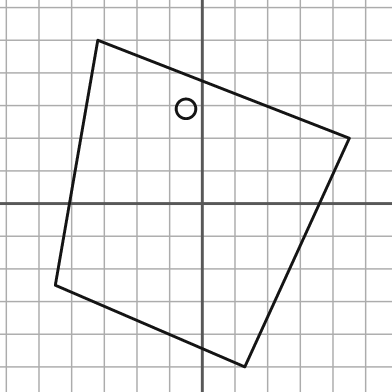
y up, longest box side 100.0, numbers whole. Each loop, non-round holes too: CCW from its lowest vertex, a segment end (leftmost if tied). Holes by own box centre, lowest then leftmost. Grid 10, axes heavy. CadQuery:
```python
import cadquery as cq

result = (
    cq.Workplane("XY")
    .moveTo(13.0, -50.0)
    .lineTo(45.0, 20.0)
    .lineTo(-32.0, 50.0)
    .lineTo(-45.0, -25.0)
    .close()
    .moveTo(-5.0, 29.0)
    .circle(3.0)
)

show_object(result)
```